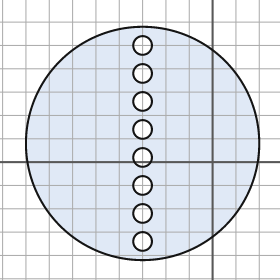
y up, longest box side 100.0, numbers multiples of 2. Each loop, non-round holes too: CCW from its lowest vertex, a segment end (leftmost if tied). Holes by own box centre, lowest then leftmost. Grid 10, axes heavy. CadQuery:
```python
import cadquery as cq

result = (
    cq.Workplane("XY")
    .moveTo(-30.0, 8.0)
    .circle(50.0)
    .moveTo(-30.0, -34.0)
    .circle(4.0)
    .moveTo(-30.0, -22.0)
    .circle(4.0)
    .moveTo(-30.0, -10.0)
    .circle(4.0)
    .moveTo(-30.0, 2.0)
    .circle(4.0)
    .moveTo(-30.0, 14.0)
    .circle(4.0)
    .moveTo(-30.0, 26.0)
    .circle(4.0)
    .moveTo(-30.0, 38.0)
    .circle(4.0)
    .moveTo(-30.0, 50.0)
    .circle(4.0)
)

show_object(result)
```